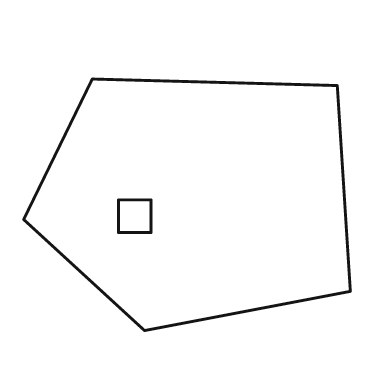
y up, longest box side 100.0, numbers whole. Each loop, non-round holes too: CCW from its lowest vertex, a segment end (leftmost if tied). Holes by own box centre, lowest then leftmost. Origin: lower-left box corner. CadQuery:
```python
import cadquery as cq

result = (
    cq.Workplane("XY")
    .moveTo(37.0, 0.0)
    .lineTo(100.0, 12.0)
    .lineTo(96.0, 75.0)
    .lineTo(21.0, 77.0)
    .lineTo(0.0, 34.0)
    .close()
    .moveTo(29.0, 30.0)
    .lineTo(39.0, 30.0)
    .lineTo(39.0, 40.0)
    .lineTo(29.0, 40.0)
    .close()
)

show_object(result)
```